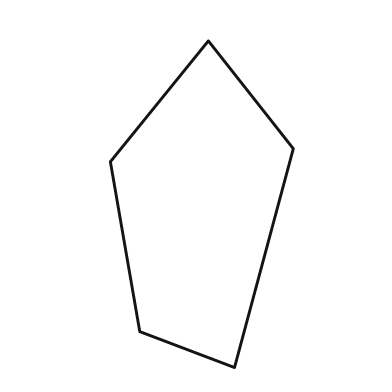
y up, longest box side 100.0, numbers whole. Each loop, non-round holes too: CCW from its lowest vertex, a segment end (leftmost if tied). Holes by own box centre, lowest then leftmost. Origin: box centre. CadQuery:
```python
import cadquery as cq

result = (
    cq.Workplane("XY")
    .moveTo(10.0, -50.0)
    .lineTo(28.0, 17.0)
    .lineTo(2.0, 50.0)
    .lineTo(-28.0, 13.0)
    .lineTo(-19.0, -39.0)
    .close()
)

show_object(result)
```